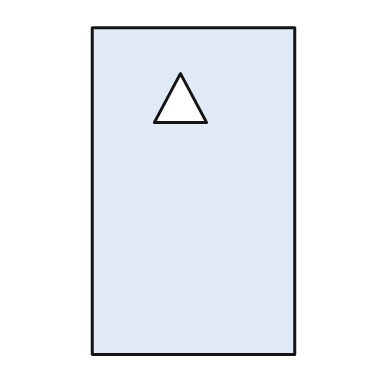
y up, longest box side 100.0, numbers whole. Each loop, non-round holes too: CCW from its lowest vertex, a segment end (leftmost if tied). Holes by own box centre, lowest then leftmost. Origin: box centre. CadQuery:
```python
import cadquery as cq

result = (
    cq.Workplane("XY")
    .moveTo(-31.0, -50.0)
    .lineTo(31.0, -50.0)
    .lineTo(31.0, 50.0)
    .lineTo(-31.0, 50.0)
    .close()
    .moveTo(-12.0, 21.0)
    .lineTo(4.0, 21.0)
    .lineTo(-4.0, 36.0)
    .close()
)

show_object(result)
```